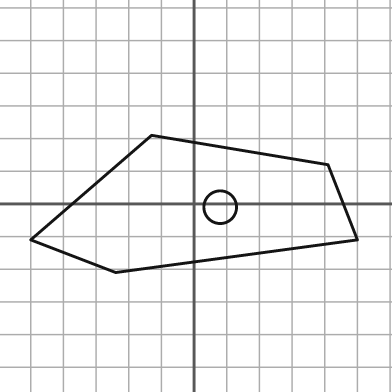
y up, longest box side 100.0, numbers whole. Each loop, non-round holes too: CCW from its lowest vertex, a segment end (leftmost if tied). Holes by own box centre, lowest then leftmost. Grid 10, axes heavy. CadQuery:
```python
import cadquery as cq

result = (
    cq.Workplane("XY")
    .moveTo(-24.0, -21.0)
    .lineTo(50.0, -11.0)
    .lineTo(41.0, 12.0)
    .lineTo(-13.0, 21.0)
    .lineTo(-50.0, -11.0)
    .close()
    .moveTo(8.0, -1.0)
    .circle(5.0)
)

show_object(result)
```